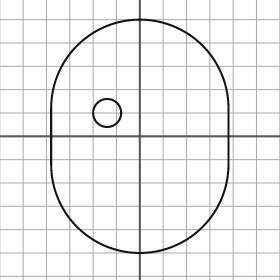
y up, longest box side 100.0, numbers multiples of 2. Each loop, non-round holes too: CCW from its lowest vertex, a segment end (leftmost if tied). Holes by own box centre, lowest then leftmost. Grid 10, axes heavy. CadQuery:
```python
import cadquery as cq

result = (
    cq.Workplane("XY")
    .moveTo(-38.0, -12.0)
    .threePointArc((0.0, -50.0), (38.0, -12.0))
    .lineTo(38.0, 12.0)
    .threePointArc((0.0, 50.0), (-38.0, 12.0))
    .close()
    .moveTo(-14.0, 10.0)
    .circle(6.0)
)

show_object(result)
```